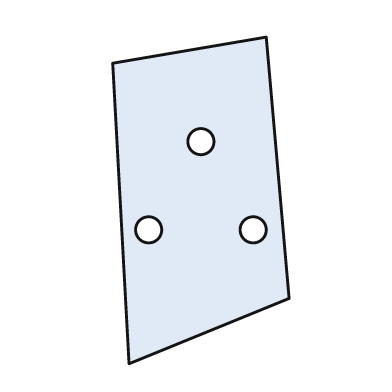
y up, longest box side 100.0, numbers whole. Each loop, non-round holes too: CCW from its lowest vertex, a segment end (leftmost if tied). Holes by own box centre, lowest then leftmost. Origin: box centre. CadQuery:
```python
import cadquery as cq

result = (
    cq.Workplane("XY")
    .moveTo(-22.0, -50.0)
    .lineTo(27.0, -30.0)
    .lineTo(20.0, 50.0)
    .lineTo(-27.0, 42.0)
    .close()
    .moveTo(-16.0, -9.0)
    .circle(4.0)
    .moveTo(16.0, -9.0)
    .circle(4.0)
    .moveTo(0.0, 18.0)
    .circle(4.0)
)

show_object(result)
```